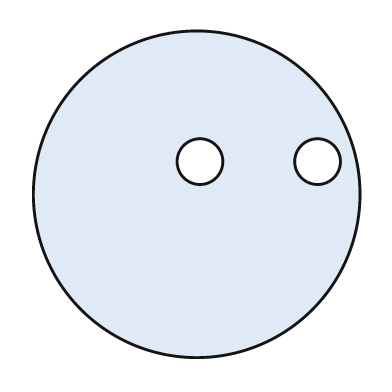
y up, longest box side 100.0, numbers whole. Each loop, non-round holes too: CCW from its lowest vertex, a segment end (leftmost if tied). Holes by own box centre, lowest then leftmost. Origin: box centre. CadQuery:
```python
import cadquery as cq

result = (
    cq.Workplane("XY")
    .moveTo(0.0, 0.0)
    .circle(50.0)
    .moveTo(1.0, 10.0)
    .circle(7.0)
    .moveTo(37.0, 10.0)
    .circle(7.0)
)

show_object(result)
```